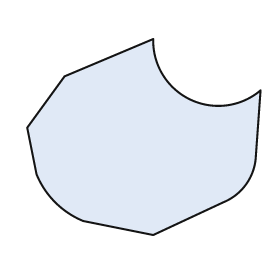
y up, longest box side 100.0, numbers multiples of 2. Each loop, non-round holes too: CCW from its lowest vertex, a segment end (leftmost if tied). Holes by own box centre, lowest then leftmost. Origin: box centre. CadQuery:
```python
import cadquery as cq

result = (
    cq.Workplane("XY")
    .moveTo(4.0, -42.0)
    .lineTo(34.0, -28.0)
    .threePointArc((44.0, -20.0), (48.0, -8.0))
    .lineTo(50.0, 20.0)
    .threePointArc((20.0, 16.0), (4.0, 42.0))
    .lineTo(-34.0, 26.0)
    .lineTo(-50.0, 4.0)
    .lineTo(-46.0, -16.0)
    .threePointArc((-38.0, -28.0), (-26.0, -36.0))
    .close()
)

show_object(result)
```